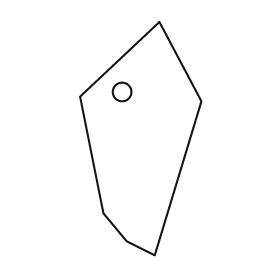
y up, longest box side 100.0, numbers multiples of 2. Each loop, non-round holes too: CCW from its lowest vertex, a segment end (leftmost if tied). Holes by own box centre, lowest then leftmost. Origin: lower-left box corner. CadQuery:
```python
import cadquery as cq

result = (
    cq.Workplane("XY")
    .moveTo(32.0, 0.0)
    .lineTo(52.0, 66.0)
    .lineTo(34.0, 100.0)
    .lineTo(0.0, 68.0)
    .lineTo(10.0, 18.0)
    .lineTo(20.0, 6.0)
    .close()
    .moveTo(18.0, 70.0)
    .circle(4.0)
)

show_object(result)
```